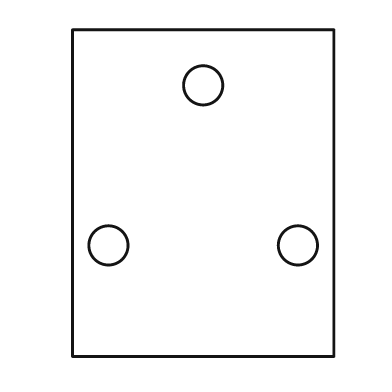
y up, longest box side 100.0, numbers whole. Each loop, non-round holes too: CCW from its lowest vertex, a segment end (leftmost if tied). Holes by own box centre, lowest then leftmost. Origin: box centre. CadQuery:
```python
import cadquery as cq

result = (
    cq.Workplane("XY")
    .moveTo(-40.0, -50.0)
    .lineTo(40.0, -50.0)
    .lineTo(40.0, 50.0)
    .lineTo(-40.0, 50.0)
    .close()
    .moveTo(-29.0, -16.0)
    .circle(6.0)
    .moveTo(29.0, -16.0)
    .circle(6.0)
    .moveTo(0.0, 33.0)
    .circle(6.0)
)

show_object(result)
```